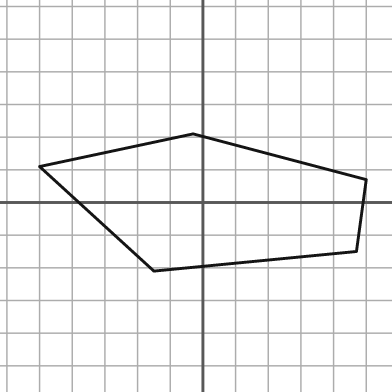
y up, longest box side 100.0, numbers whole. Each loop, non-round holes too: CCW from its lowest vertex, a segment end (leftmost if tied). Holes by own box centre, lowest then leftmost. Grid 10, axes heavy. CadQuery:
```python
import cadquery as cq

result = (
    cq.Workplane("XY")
    .moveTo(-15.0, -21.0)
    .lineTo(47.0, -15.0)
    .lineTo(50.0, 7.0)
    .lineTo(-3.0, 21.0)
    .lineTo(-50.0, 11.0)
    .close()
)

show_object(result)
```